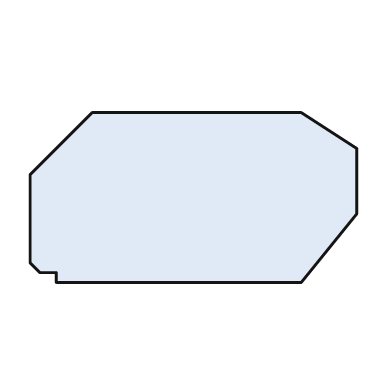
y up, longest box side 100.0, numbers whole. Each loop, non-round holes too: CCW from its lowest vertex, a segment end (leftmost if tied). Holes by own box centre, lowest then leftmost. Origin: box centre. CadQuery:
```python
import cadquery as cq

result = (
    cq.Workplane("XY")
    .moveTo(-42.0, -26.0)
    .lineTo(33.0, -26.0)
    .lineTo(50.0, -5.0)
    .lineTo(50.0, 15.0)
    .lineTo(33.0, 26.0)
    .lineTo(-31.0, 26.0)
    .lineTo(-50.0, 7.0)
    .lineTo(-50.0, -20.0)
    .lineTo(-47.0, -23.0)
    .lineTo(-42.0, -23.0)
    .close()
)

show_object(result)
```